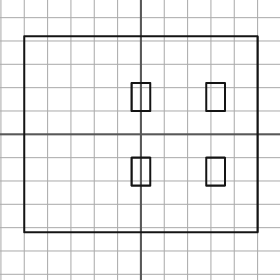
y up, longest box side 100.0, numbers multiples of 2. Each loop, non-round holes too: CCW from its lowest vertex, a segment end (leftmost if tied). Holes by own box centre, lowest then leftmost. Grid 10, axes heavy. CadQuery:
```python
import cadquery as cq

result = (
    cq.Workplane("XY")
    .moveTo(-50.0, -42.0)
    .lineTo(50.0, -42.0)
    .lineTo(50.0, 42.0)
    .lineTo(-50.0, 42.0)
    .close()
    .moveTo(-4.0, -22.0)
    .lineTo(4.0, -22.0)
    .lineTo(4.0, -10.0)
    .lineTo(-4.0, -10.0)
    .close()
    .moveTo(28.0, -22.0)
    .lineTo(36.0, -22.0)
    .lineTo(36.0, -10.0)
    .lineTo(28.0, -10.0)
    .close()
    .moveTo(-4.0, 10.0)
    .lineTo(4.0, 10.0)
    .lineTo(4.0, 22.0)
    .lineTo(-4.0, 22.0)
    .close()
    .moveTo(28.0, 10.0)
    .lineTo(36.0, 10.0)
    .lineTo(36.0, 22.0)
    .lineTo(28.0, 22.0)
    .close()
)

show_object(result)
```